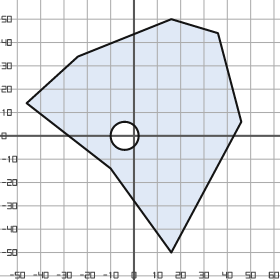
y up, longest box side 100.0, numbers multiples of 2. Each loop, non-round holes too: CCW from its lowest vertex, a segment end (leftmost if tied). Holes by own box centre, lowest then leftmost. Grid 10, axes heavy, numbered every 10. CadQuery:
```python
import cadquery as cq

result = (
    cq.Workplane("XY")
    .moveTo(16.0, -50.0)
    .lineTo(46.0, 6.0)
    .lineTo(36.0, 44.0)
    .lineTo(16.0, 50.0)
    .lineTo(-24.0, 34.0)
    .lineTo(-46.0, 14.0)
    .lineTo(-10.0, -14.0)
    .close()
    .moveTo(-4.0, 0.0)
    .circle(6.0)
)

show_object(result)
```